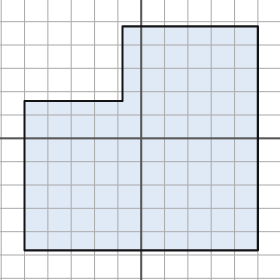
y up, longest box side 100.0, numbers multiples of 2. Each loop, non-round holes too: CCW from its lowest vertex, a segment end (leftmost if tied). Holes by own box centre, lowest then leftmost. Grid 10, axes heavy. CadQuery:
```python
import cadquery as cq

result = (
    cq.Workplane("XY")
    .moveTo(-50.0, -48.0)
    .lineTo(50.0, -48.0)
    .lineTo(50.0, 48.0)
    .lineTo(-8.0, 48.0)
    .lineTo(-8.0, 16.0)
    .lineTo(-50.0, 16.0)
    .close()
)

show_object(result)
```